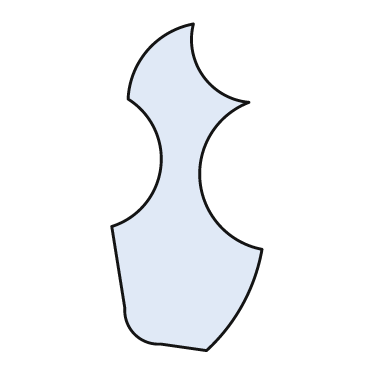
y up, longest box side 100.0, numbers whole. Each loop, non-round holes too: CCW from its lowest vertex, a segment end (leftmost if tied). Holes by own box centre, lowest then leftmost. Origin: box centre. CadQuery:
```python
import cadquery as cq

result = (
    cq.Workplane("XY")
    .moveTo(6.0, -50.0)
    .threePointArc((17.0, -36.0), (23.0, -19.0))
    .threePointArc((4.0, 2.0), (19.0, 26.0))
    .threePointArc((5.0, 34.0), (2.0, 50.0))
    .threePointArc((-12.0, 42.0), (-18.0, 27.0))
    .threePointArc((-8.0, 6.0), (-23.0, -12.0))
    .lineTo(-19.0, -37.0)
    .threePointArc((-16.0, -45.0), (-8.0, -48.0))
    .close()
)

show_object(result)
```